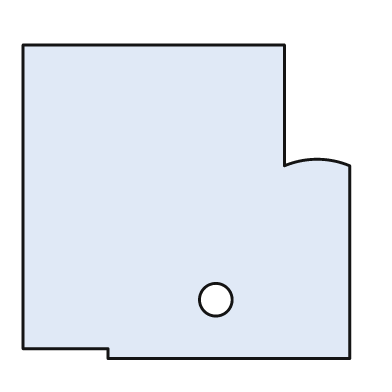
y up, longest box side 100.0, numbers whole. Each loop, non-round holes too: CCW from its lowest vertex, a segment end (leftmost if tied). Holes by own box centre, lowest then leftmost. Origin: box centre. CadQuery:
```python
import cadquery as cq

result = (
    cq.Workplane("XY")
    .moveTo(-24.0, -48.0)
    .lineTo(50.0, -48.0)
    .lineTo(50.0, 11.0)
    .threePointArc((40.0, 13.0), (30.0, 11.0))
    .lineTo(30.0, 48.0)
    .lineTo(-50.0, 48.0)
    .lineTo(-50.0, -45.0)
    .lineTo(-24.0, -45.0)
    .close()
    .moveTo(9.0, -30.0)
    .circle(5.0)
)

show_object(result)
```